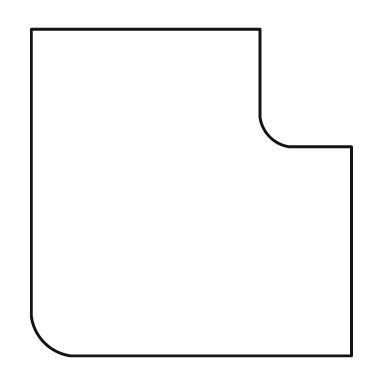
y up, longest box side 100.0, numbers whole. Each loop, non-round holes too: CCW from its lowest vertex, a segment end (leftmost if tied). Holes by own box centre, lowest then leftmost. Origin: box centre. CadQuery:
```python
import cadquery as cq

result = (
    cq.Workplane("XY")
    .moveTo(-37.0, -50.0)
    .lineTo(49.0, -50.0)
    .lineTo(49.0, 14.0)
    .lineTo(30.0, 14.0)
    .threePointArc((24.0, 17.0), (21.0, 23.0))
    .lineTo(21.0, 50.0)
    .lineTo(-49.0, 50.0)
    .lineTo(-49.0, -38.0)
    .threePointArc((-45.0, -46.0), (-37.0, -50.0))
    .close()
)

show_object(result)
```